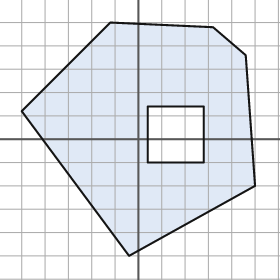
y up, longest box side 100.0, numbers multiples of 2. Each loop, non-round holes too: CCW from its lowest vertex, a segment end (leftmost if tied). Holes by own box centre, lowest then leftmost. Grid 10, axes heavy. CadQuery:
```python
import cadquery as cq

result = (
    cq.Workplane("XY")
    .moveTo(-4.0, -50.0)
    .lineTo(50.0, -20.0)
    .lineTo(46.0, 36.0)
    .lineTo(32.0, 48.0)
    .lineTo(-12.0, 50.0)
    .lineTo(-50.0, 12.0)
    .close()
    .moveTo(4.0, -10.0)
    .lineTo(28.0, -10.0)
    .lineTo(28.0, 14.0)
    .lineTo(4.0, 14.0)
    .close()
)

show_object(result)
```